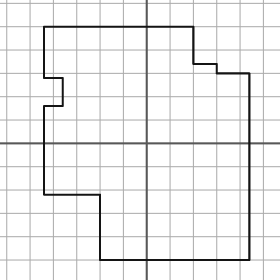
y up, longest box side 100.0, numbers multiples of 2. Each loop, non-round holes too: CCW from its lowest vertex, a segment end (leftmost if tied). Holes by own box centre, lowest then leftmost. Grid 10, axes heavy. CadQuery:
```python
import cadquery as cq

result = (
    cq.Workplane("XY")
    .moveTo(-20.0, -50.0)
    .lineTo(44.0, -50.0)
    .lineTo(44.0, 30.0)
    .lineTo(30.0, 30.0)
    .lineTo(30.0, 34.0)
    .lineTo(20.0, 34.0)
    .lineTo(20.0, 50.0)
    .lineTo(-44.0, 50.0)
    .lineTo(-44.0, 28.0)
    .lineTo(-36.0, 28.0)
    .lineTo(-36.0, 16.0)
    .lineTo(-44.0, 16.0)
    .lineTo(-44.0, -22.0)
    .lineTo(-20.0, -22.0)
    .close()
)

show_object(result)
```